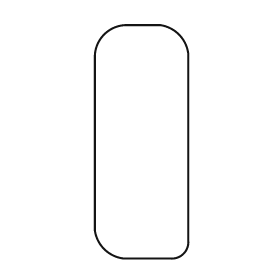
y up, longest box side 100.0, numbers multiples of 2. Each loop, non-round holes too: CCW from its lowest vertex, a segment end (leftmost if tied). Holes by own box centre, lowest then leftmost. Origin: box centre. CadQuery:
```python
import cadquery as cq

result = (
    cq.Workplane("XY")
    .moveTo(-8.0, -50.0)
    .lineTo(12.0, -50.0)
    .threePointArc((18.0, -48.0), (20.0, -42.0))
    .lineTo(20.0, 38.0)
    .threePointArc((16.0, 46.0), (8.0, 50.0))
    .lineTo(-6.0, 50.0)
    .threePointArc((-16.0, 46.0), (-20.0, 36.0))
    .lineTo(-20.0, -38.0)
    .threePointArc((-16.0, -46.0), (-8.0, -50.0))
    .close()
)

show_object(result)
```